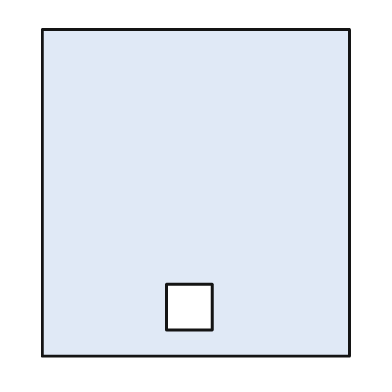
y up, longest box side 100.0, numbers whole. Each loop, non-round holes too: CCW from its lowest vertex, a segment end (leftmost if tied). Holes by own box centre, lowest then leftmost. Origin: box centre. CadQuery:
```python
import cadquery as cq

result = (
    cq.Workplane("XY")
    .moveTo(-47.0, -50.0)
    .lineTo(47.0, -50.0)
    .lineTo(47.0, 50.0)
    .lineTo(-47.0, 50.0)
    .close()
    .moveTo(-9.0, -42.0)
    .lineTo(5.0, -42.0)
    .lineTo(5.0, -28.0)
    .lineTo(-9.0, -28.0)
    .close()
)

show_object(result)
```